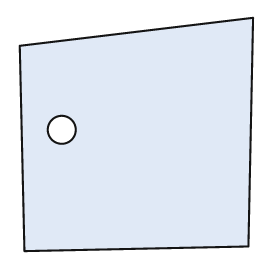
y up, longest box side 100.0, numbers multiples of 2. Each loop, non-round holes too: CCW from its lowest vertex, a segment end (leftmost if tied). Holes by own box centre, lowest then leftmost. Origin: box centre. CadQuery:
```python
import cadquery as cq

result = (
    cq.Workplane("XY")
    .moveTo(-48.0, -50.0)
    .lineTo(48.0, -48.0)
    .lineTo(50.0, 50.0)
    .lineTo(-50.0, 38.0)
    .close()
    .moveTo(-32.0, 2.0)
    .circle(6.0)
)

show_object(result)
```